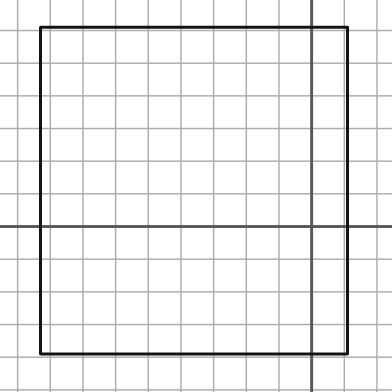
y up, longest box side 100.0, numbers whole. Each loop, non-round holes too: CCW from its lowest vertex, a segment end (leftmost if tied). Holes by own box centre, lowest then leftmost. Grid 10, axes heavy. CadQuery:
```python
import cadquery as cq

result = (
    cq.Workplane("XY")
    .moveTo(-83.0, -39.0)
    .lineTo(11.0, -39.0)
    .lineTo(11.0, 61.0)
    .lineTo(-83.0, 61.0)
    .close()
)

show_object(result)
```